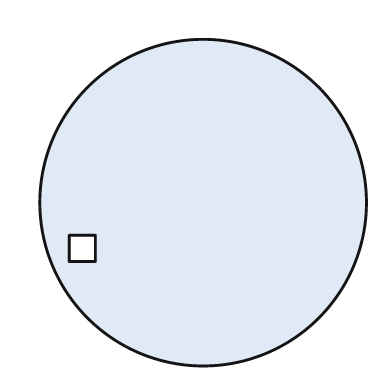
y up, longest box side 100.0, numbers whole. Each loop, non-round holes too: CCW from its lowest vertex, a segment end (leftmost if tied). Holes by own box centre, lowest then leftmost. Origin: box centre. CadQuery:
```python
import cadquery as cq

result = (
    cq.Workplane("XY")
    .moveTo(0.0, 0.0)
    .circle(50.0)
    .moveTo(-41.0, -18.0)
    .lineTo(-33.0, -18.0)
    .lineTo(-33.0, -10.0)
    .lineTo(-41.0, -10.0)
    .close()
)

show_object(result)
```